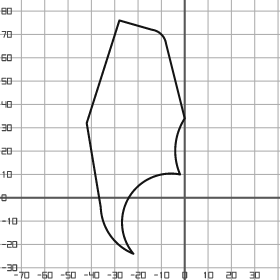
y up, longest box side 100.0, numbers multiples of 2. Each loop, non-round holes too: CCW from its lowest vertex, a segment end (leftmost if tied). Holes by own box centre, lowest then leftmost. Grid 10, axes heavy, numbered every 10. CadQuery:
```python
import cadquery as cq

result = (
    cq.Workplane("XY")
    .moveTo(-22.0, -24.0)
    .threePointArc((-24.0, 0.0), (-2.0, 10.0))
    .threePointArc((-4.0, 22.0), (0.0, 34.0))
    .lineTo(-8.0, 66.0)
    .threePointArc((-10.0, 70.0), (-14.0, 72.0))
    .lineTo(-28.0, 76.0)
    .lineTo(-42.0, 32.0)
    .lineTo(-36.0, -4.0)
    .threePointArc((-32.0, -16.0), (-22.0, -24.0))
    .close()
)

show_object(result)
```